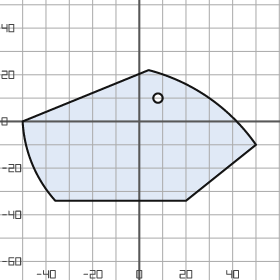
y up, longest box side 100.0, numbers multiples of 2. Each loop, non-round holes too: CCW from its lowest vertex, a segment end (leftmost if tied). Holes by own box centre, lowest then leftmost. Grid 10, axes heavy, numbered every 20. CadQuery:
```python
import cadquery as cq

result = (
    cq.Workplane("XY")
    .moveTo(-36.0, -34.0)
    .lineTo(20.0, -34.0)
    .lineTo(50.0, -10.0)
    .threePointArc((30.0, 10.0), (4.0, 22.0))
    .lineTo(-50.0, 0.0)
    .threePointArc((-46.0, -18.0), (-36.0, -34.0))
    .close()
    .moveTo(8.0, 10.0)
    .circle(2.0)
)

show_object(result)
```